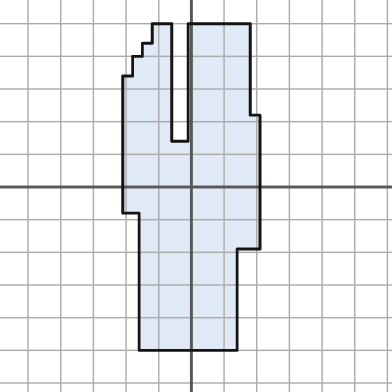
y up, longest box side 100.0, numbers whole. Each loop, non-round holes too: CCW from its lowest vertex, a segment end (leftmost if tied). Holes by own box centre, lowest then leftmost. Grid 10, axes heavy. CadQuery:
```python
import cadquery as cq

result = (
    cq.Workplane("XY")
    .moveTo(-16.0, -50.0)
    .lineTo(14.0, -50.0)
    .lineTo(14.0, -19.0)
    .lineTo(21.0, -19.0)
    .lineTo(21.0, 22.0)
    .lineTo(18.0, 22.0)
    .lineTo(18.0, 50.0)
    .lineTo(-1.0, 50.0)
    .lineTo(-1.0, 14.0)
    .lineTo(-6.0, 14.0)
    .lineTo(-6.0, 50.0)
    .lineTo(-12.0, 50.0)
    .lineTo(-12.0, 44.0)
    .lineTo(-15.0, 44.0)
    .lineTo(-15.0, 40.0)
    .lineTo(-18.0, 40.0)
    .lineTo(-18.0, 34.0)
    .lineTo(-21.0, 34.0)
    .lineTo(-21.0, -8.0)
    .lineTo(-16.0, -8.0)
    .close()
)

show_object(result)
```